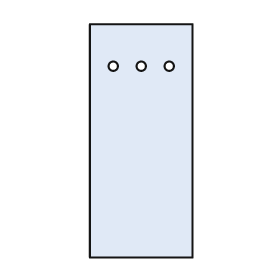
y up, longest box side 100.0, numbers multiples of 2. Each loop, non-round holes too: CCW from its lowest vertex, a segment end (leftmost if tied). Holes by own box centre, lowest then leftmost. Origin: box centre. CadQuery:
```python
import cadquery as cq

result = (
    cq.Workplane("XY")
    .moveTo(-22.0, -50.0)
    .lineTo(22.0, -50.0)
    .lineTo(22.0, 50.0)
    .lineTo(-22.0, 50.0)
    .close()
    .moveTo(-12.0, 32.0)
    .circle(2.0)
    .moveTo(0.0, 32.0)
    .circle(2.0)
    .moveTo(12.0, 32.0)
    .circle(2.0)
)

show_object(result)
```